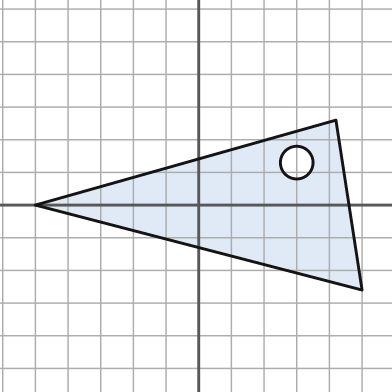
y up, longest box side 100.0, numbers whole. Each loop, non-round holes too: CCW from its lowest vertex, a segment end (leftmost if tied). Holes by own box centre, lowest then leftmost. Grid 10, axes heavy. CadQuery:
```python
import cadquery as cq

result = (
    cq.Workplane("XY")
    .moveTo(50.0, -26.0)
    .lineTo(42.0, 26.0)
    .lineTo(-50.0, 0.0)
    .close()
    .moveTo(30.0, 13.0)
    .circle(5.0)
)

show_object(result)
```